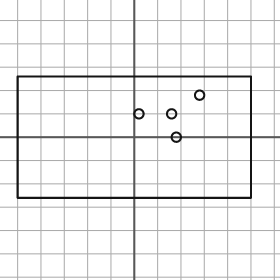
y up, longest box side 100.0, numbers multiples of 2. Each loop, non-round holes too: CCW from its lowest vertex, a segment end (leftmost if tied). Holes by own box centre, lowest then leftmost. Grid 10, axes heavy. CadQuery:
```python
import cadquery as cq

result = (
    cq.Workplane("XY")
    .moveTo(-50.0, -26.0)
    .lineTo(50.0, -26.0)
    .lineTo(50.0, 26.0)
    .lineTo(-50.0, 26.0)
    .close()
    .moveTo(18.0, 0.0)
    .circle(2.0)
    .moveTo(2.0, 10.0)
    .circle(2.0)
    .moveTo(16.0, 10.0)
    .circle(2.0)
    .moveTo(28.0, 18.0)
    .circle(2.0)
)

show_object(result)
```